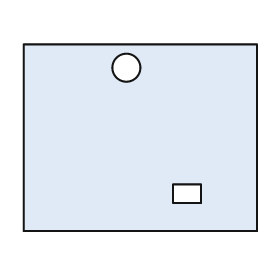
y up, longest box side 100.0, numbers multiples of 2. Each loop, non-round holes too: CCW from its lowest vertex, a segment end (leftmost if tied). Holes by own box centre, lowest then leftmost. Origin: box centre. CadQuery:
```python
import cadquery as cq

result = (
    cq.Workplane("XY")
    .moveTo(-50.0, -40.0)
    .lineTo(50.0, -40.0)
    .lineTo(50.0, 40.0)
    .lineTo(-50.0, 40.0)
    .close()
    .moveTo(14.0, -28.0)
    .lineTo(26.0, -28.0)
    .lineTo(26.0, -20.0)
    .lineTo(14.0, -20.0)
    .close()
    .moveTo(-6.0, 30.0)
    .circle(6.0)
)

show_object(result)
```